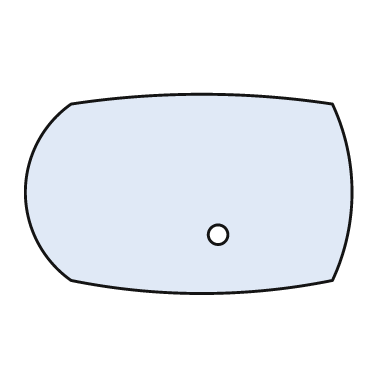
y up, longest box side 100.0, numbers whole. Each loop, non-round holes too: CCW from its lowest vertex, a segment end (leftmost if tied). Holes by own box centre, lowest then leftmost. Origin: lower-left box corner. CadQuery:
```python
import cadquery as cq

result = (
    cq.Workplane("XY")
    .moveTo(14.0, 4.0)
    .threePointArc((54.0, 0.0), (94.0, 4.0))
    .threePointArc((100.0, 31.0), (94.0, 58.0))
    .threePointArc((54.0, 61.0), (14.0, 58.0))
    .threePointArc((0.0, 31.0), (14.0, 4.0))
    .close()
    .moveTo(59.0, 18.0)
    .circle(3.0)
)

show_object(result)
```